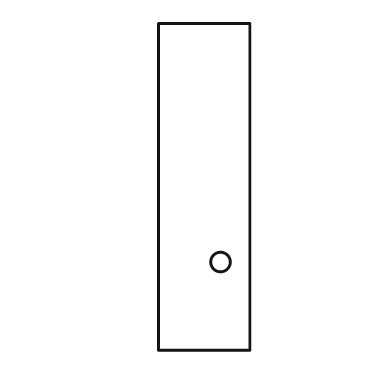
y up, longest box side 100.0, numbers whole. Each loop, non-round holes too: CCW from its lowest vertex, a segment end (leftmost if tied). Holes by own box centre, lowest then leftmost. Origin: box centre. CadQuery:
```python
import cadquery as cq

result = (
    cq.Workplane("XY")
    .moveTo(-14.0, -50.0)
    .lineTo(14.0, -50.0)
    .lineTo(14.0, 50.0)
    .lineTo(-14.0, 50.0)
    .close()
    .moveTo(5.0, -23.0)
    .circle(3.0)
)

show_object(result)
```